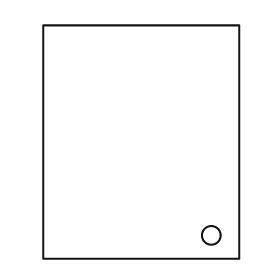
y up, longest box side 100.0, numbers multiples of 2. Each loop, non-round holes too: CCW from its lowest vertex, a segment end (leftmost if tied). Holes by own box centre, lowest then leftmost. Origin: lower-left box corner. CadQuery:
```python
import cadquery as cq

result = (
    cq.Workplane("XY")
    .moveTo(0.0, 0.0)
    .lineTo(84.0, 0.0)
    .lineTo(84.0, 100.0)
    .lineTo(0.0, 100.0)
    .close()
    .moveTo(72.0, 10.0)
    .circle(4.0)
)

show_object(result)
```